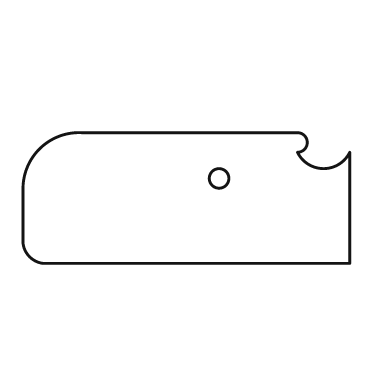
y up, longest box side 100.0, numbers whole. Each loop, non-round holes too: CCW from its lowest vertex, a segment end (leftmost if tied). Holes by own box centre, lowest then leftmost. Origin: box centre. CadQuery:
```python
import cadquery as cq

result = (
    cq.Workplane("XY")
    .moveTo(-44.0, -20.0)
    .lineTo(50.0, -20.0)
    .lineTo(50.0, 14.0)
    .threePointArc((42.0, 9.0), (34.0, 14.0))
    .threePointArc((37.0, 17.0), (34.0, 20.0))
    .lineTo(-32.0, 20.0)
    .threePointArc((-45.0, 15.0), (-50.0, 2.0))
    .lineTo(-50.0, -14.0)
    .threePointArc((-48.0, -18.0), (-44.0, -20.0))
    .close()
    .moveTo(10.0, 6.0)
    .circle(3.0)
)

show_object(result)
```